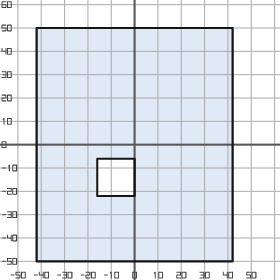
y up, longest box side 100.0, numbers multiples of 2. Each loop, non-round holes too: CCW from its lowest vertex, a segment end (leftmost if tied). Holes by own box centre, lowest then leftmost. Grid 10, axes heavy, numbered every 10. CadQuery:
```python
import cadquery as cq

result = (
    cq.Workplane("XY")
    .moveTo(-42.0, -50.0)
    .lineTo(42.0, -50.0)
    .lineTo(42.0, 50.0)
    .lineTo(-42.0, 50.0)
    .close()
    .moveTo(-16.0, -22.0)
    .lineTo(0.0, -22.0)
    .lineTo(0.0, -6.0)
    .lineTo(-16.0, -6.0)
    .close()
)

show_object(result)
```